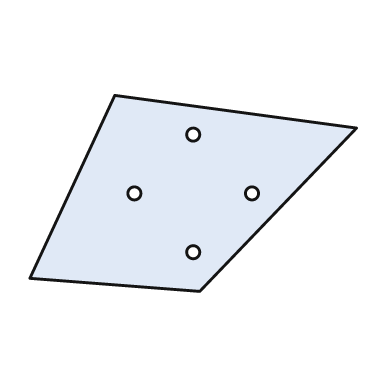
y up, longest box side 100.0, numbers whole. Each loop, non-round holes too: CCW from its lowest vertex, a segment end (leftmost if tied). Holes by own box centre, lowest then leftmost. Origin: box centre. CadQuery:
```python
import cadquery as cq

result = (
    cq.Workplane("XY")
    .moveTo(2.0, -30.0)
    .lineTo(50.0, 20.0)
    .lineTo(-24.0, 30.0)
    .lineTo(-50.0, -26.0)
    .close()
    .moveTo(0.0, -18.0)
    .circle(2.0)
    .moveTo(-18.0, 0.0)
    .circle(2.0)
    .moveTo(18.0, 0.0)
    .circle(2.0)
    .moveTo(0.0, 18.0)
    .circle(2.0)
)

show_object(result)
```